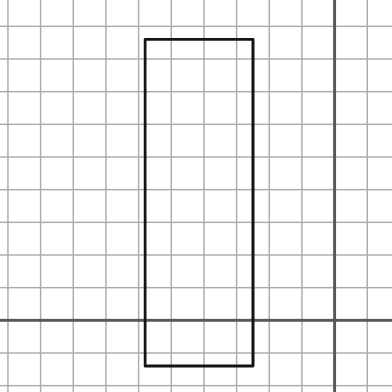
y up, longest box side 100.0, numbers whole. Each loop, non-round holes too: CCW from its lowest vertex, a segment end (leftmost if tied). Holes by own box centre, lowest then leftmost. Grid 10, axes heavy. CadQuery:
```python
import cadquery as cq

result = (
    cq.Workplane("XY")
    .moveTo(-58.0, -14.0)
    .lineTo(-25.0, -14.0)
    .lineTo(-25.0, 86.0)
    .lineTo(-58.0, 86.0)
    .close()
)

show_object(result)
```